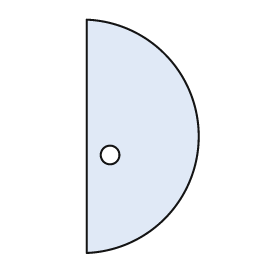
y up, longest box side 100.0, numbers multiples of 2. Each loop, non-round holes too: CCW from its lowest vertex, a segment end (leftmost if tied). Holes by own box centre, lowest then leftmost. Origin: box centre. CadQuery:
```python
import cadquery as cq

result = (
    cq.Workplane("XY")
    .moveTo(-24.0, -50.0)
    .threePointArc((24.0, 0.0), (-24.0, 50.0))
    .close()
    .moveTo(-14.0, -8.0)
    .circle(4.0)
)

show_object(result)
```